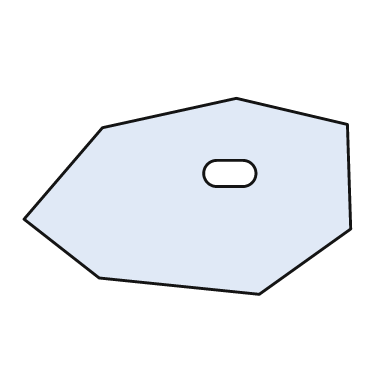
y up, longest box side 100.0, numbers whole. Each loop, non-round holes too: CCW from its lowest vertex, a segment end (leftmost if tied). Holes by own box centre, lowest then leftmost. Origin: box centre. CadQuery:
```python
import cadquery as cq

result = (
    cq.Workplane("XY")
    .moveTo(22.0, -30.0)
    .lineTo(50.0, -10.0)
    .lineTo(49.0, 22.0)
    .lineTo(15.0, 30.0)
    .lineTo(-26.0, 21.0)
    .lineTo(-50.0, -7.0)
    .lineTo(-27.0, -25.0)
    .close()
    .moveTo(9.0, 3.0)
    .lineTo(17.0, 3.0)
    .threePointArc((21.0, 7.0), (17.0, 11.0))
    .lineTo(9.0, 11.0)
    .threePointArc((5.0, 7.0), (9.0, 3.0))
    .close()
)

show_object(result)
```